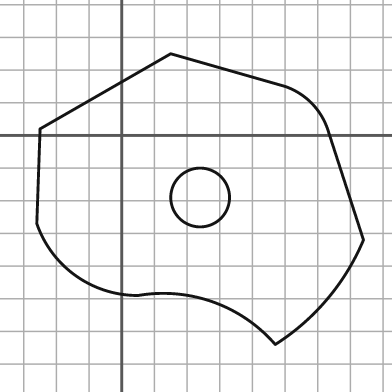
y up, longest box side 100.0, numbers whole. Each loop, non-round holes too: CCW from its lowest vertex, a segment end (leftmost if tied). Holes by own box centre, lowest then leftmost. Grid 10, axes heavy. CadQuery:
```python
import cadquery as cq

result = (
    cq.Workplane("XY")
    .moveTo(47.0, -64.0)
    .threePointArc((63.0, -50.0), (74.0, -32.0))
    .lineTo(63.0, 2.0)
    .threePointArc((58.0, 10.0), (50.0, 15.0))
    .lineTo(15.0, 25.0)
    .lineTo(-25.0, 2.0)
    .lineTo(-26.0, -27.0)
    .threePointArc((-14.0, -43.0), (5.0, -49.0))
    .threePointArc((28.0, -51.0), (47.0, -64.0))
    .close()
    .moveTo(24.0, -19.0)
    .circle(9.0)
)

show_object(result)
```